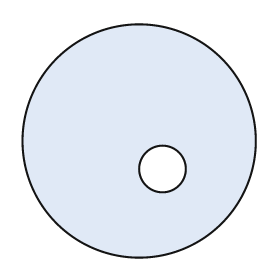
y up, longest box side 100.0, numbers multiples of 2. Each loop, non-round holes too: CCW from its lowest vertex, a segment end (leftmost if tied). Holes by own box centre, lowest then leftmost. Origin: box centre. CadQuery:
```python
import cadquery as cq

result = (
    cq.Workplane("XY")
    .moveTo(0.0, 0.0)
    .circle(50.0)
    .moveTo(10.0, -12.0)
    .circle(10.0)
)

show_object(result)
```